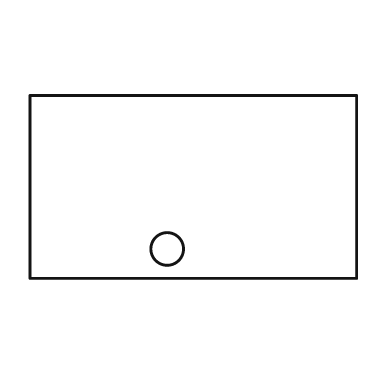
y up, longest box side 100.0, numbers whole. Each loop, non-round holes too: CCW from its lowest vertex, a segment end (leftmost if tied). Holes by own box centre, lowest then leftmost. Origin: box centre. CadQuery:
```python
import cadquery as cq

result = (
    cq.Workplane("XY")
    .moveTo(-50.0, -28.0)
    .lineTo(50.0, -28.0)
    .lineTo(50.0, 28.0)
    .lineTo(-50.0, 28.0)
    .close()
    .moveTo(-8.0, -19.0)
    .circle(5.0)
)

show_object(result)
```